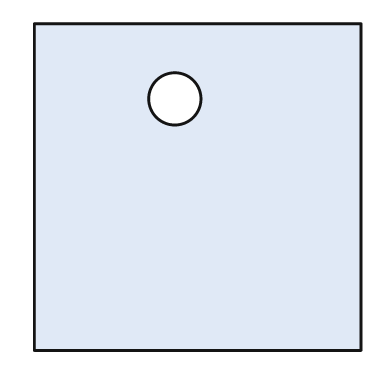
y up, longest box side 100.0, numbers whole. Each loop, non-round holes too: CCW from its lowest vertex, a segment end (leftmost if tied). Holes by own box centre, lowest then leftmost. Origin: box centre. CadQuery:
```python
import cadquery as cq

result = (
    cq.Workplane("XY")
    .moveTo(-50.0, -50.0)
    .lineTo(50.0, -50.0)
    .lineTo(50.0, 50.0)
    .lineTo(-50.0, 50.0)
    .close()
    .moveTo(-7.0, 27.0)
    .circle(8.0)
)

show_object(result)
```